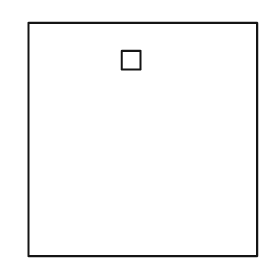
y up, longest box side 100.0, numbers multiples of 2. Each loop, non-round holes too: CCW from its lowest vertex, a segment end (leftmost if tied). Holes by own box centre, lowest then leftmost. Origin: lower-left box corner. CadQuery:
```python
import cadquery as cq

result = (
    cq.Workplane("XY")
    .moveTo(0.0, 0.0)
    .lineTo(98.0, 0.0)
    .lineTo(98.0, 100.0)
    .lineTo(0.0, 100.0)
    .close()
    .moveTo(40.0, 80.0)
    .lineTo(48.0, 80.0)
    .lineTo(48.0, 88.0)
    .lineTo(40.0, 88.0)
    .close()
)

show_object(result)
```